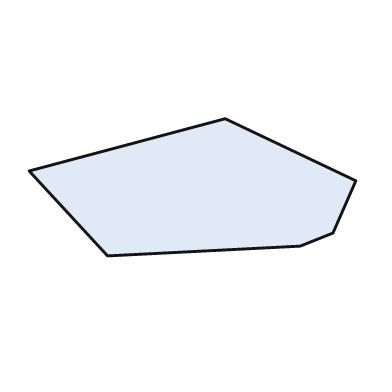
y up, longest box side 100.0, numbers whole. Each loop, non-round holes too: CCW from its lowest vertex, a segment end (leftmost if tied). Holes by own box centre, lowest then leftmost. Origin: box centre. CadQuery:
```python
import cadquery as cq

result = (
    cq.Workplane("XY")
    .moveTo(-26.0, -21.0)
    .lineTo(33.0, -18.0)
    .lineTo(43.0, -14.0)
    .lineTo(50.0, 2.0)
    .lineTo(10.0, 21.0)
    .lineTo(-50.0, 5.0)
    .close()
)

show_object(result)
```